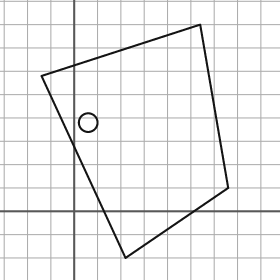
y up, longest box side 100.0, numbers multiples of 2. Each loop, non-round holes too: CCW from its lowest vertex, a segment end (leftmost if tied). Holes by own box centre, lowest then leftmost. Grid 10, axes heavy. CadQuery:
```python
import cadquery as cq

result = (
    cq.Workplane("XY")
    .moveTo(22.0, -20.0)
    .lineTo(66.0, 10.0)
    .lineTo(54.0, 80.0)
    .lineTo(-14.0, 58.0)
    .close()
    .moveTo(6.0, 38.0)
    .circle(4.0)
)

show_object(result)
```